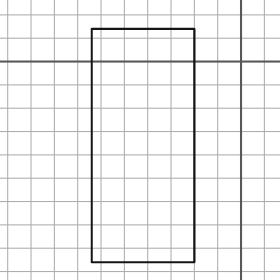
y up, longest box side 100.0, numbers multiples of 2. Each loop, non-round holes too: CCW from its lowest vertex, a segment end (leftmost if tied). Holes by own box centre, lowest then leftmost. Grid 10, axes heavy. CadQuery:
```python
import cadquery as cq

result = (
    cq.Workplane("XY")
    .moveTo(-64.0, -86.0)
    .lineTo(-20.0, -86.0)
    .lineTo(-20.0, 14.0)
    .lineTo(-64.0, 14.0)
    .close()
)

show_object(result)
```